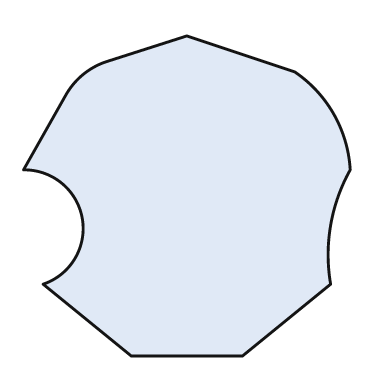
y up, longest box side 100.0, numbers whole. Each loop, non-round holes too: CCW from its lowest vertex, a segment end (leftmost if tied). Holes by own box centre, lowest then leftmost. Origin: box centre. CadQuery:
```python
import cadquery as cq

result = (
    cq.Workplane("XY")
    .moveTo(-17.0, -49.0)
    .lineTo(17.0, -49.0)
    .lineTo(44.0, -27.0)
    .threePointArc((44.0, -9.0), (50.0, 8.0))
    .threePointArc((45.0, 25.0), (33.0, 38.0))
    .lineTo(0.0, 49.0)
    .lineTo(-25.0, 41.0)
    .threePointArc((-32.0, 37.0), (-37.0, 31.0))
    .lineTo(-50.0, 8.0)
    .threePointArc((-32.0, -7.0), (-44.0, -27.0))
    .close()
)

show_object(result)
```